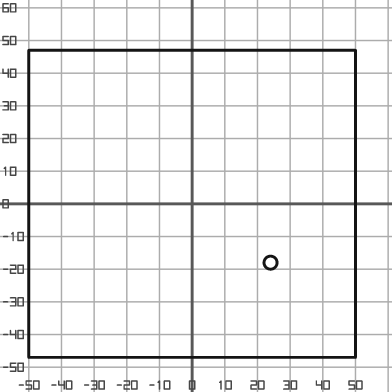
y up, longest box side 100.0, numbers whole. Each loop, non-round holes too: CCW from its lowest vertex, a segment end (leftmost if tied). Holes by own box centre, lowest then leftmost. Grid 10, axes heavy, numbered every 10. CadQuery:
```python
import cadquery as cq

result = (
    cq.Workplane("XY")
    .moveTo(-50.0, -47.0)
    .lineTo(50.0, -47.0)
    .lineTo(50.0, 47.0)
    .lineTo(-50.0, 47.0)
    .close()
    .moveTo(24.0, -18.0)
    .circle(2.0)
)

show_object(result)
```